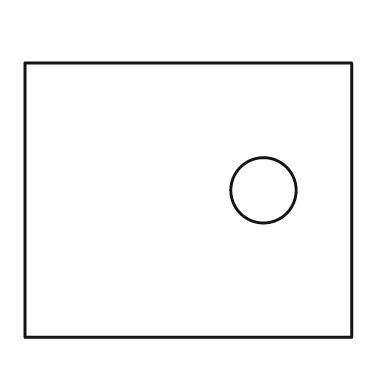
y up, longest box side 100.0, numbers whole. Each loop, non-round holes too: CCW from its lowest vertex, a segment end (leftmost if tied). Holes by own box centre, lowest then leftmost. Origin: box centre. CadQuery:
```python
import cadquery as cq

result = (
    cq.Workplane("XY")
    .moveTo(-50.0, -42.0)
    .lineTo(50.0, -42.0)
    .lineTo(50.0, 42.0)
    .lineTo(-50.0, 42.0)
    .close()
    .moveTo(23.0, 3.0)
    .circle(10.0)
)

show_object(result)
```